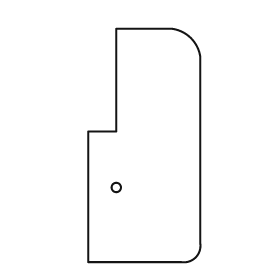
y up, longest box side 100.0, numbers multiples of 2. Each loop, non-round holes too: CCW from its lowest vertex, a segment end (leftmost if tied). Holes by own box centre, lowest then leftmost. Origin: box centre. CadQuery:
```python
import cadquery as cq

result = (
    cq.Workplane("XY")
    .moveTo(-24.0, -50.0)
    .lineTo(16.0, -50.0)
    .threePointArc((22.0, -48.0), (24.0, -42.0))
    .lineTo(24.0, 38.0)
    .threePointArc((20.0, 46.0), (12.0, 50.0))
    .lineTo(-12.0, 50.0)
    .lineTo(-12.0, 6.0)
    .lineTo(-24.0, 6.0)
    .close()
    .moveTo(-12.0, -18.0)
    .circle(2.0)
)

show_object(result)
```